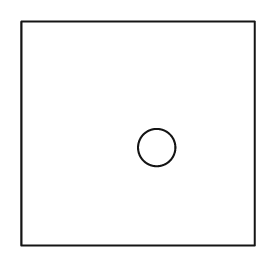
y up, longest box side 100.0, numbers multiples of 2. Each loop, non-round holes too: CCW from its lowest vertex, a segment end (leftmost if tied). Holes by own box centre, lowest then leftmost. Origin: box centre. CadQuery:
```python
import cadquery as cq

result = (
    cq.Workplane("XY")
    .moveTo(-50.0, -48.0)
    .lineTo(50.0, -48.0)
    .lineTo(50.0, 48.0)
    .lineTo(-50.0, 48.0)
    .close()
    .moveTo(8.0, -6.0)
    .circle(8.0)
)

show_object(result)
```